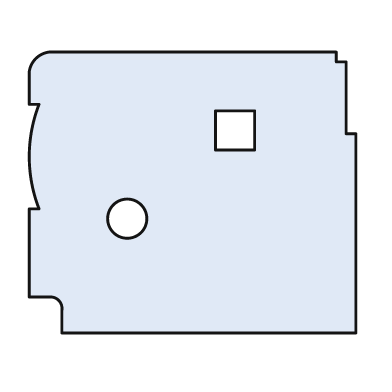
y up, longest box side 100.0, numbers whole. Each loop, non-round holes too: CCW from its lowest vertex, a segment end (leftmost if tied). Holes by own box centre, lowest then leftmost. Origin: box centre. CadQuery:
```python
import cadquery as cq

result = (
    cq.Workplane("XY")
    .moveTo(-40.0, -43.0)
    .lineTo(50.0, -43.0)
    .lineTo(50.0, 18.0)
    .lineTo(47.0, 18.0)
    .lineTo(47.0, 40.0)
    .lineTo(44.0, 40.0)
    .lineTo(44.0, 43.0)
    .lineTo(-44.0, 43.0)
    .threePointArc((-48.0, 41.0), (-50.0, 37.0))
    .lineTo(-50.0, 27.0)
    .lineTo(-47.0, 27.0)
    .threePointArc((-50.0, 11.0), (-47.0, -5.0))
    .lineTo(-50.0, -5.0)
    .lineTo(-50.0, -32.0)
    .lineTo(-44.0, -32.0)
    .threePointArc((-41.0, -33.0), (-40.0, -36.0))
    .close()
    .moveTo(-20.0, -8.0)
    .circle(6.0)
    .moveTo(7.0, 13.0)
    .lineTo(19.0, 13.0)
    .lineTo(19.0, 25.0)
    .lineTo(7.0, 25.0)
    .close()
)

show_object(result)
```